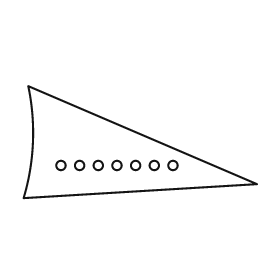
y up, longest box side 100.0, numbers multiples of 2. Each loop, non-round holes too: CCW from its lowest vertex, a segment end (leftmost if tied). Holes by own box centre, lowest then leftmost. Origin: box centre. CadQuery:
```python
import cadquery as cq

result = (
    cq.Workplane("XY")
    .moveTo(-50.0, -24.0)
    .lineTo(50.0, -18.0)
    .lineTo(-48.0, 24.0)
    .threePointArc((-46.0, 0.0), (-50.0, -24.0))
    .close()
    .moveTo(-34.0, -10.0)
    .circle(2.0)
    .moveTo(-26.0, -10.0)
    .circle(2.0)
    .moveTo(-18.0, -10.0)
    .circle(2.0)
    .moveTo(-10.0, -10.0)
    .circle(2.0)
    .moveTo(-2.0, -10.0)
    .circle(2.0)
    .moveTo(6.0, -10.0)
    .circle(2.0)
    .moveTo(14.0, -10.0)
    .circle(2.0)
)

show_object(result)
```